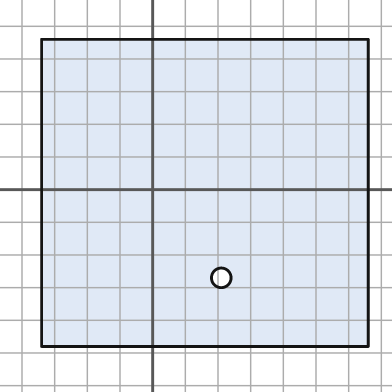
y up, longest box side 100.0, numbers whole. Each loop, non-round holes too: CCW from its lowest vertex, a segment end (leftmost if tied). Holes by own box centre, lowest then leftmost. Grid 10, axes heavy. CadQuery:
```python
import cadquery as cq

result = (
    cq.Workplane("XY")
    .moveTo(-34.0, -48.0)
    .lineTo(66.0, -48.0)
    .lineTo(66.0, 46.0)
    .lineTo(-34.0, 46.0)
    .close()
    .moveTo(21.0, -27.0)
    .circle(3.0)
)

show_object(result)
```